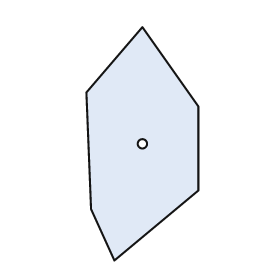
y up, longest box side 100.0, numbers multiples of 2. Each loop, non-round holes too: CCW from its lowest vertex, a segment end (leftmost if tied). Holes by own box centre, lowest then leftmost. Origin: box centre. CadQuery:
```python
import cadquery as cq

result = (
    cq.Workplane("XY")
    .moveTo(-12.0, -50.0)
    .lineTo(24.0, -20.0)
    .lineTo(24.0, 16.0)
    .lineTo(0.0, 50.0)
    .lineTo(-24.0, 22.0)
    .lineTo(-22.0, -28.0)
    .close()
    .moveTo(0.0, 0.0)
    .circle(2.0)
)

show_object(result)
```